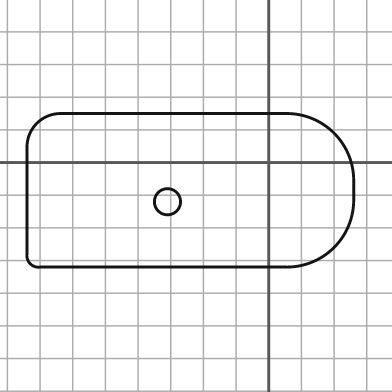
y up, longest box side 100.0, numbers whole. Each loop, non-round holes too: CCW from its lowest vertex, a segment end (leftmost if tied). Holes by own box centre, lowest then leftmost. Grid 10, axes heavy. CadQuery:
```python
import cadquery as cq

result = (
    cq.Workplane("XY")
    .moveTo(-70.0, -32.0)
    .lineTo(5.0, -32.0)
    .threePointArc((20.0, -26.0), (26.0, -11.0))
    .lineTo(26.0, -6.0)
    .threePointArc((20.0, 9.0), (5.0, 15.0))
    .lineTo(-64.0, 15.0)
    .threePointArc((-71.0, 12.0), (-74.0, 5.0))
    .lineTo(-74.0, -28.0)
    .threePointArc((-73.0, -31.0), (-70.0, -32.0))
    .close()
    .moveTo(-31.0, -12.0)
    .circle(4.0)
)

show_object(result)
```